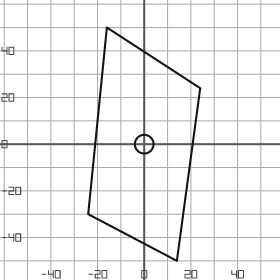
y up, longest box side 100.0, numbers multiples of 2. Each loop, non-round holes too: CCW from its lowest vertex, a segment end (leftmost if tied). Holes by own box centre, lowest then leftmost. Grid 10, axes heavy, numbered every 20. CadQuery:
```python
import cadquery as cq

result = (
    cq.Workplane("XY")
    .moveTo(14.0, -50.0)
    .lineTo(24.0, 24.0)
    .lineTo(-16.0, 50.0)
    .lineTo(-24.0, -30.0)
    .close()
    .moveTo(0.0, 0.0)
    .circle(4.0)
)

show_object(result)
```